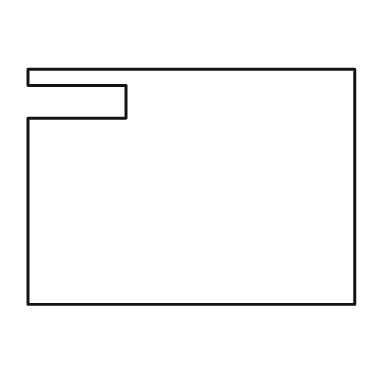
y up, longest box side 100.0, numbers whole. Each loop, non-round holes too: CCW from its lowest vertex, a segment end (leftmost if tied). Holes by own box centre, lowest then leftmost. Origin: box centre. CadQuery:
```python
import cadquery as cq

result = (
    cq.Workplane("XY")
    .moveTo(-50.0, -36.0)
    .lineTo(50.0, -36.0)
    .lineTo(50.0, 36.0)
    .lineTo(-50.0, 36.0)
    .lineTo(-50.0, 31.0)
    .lineTo(-20.0, 31.0)
    .lineTo(-20.0, 21.0)
    .lineTo(-50.0, 21.0)
    .close()
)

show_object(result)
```